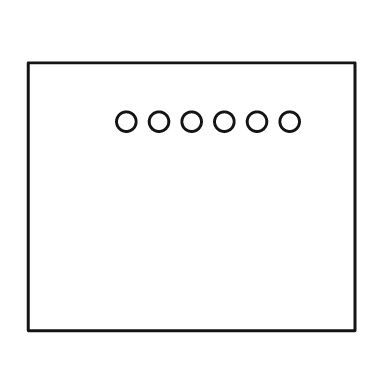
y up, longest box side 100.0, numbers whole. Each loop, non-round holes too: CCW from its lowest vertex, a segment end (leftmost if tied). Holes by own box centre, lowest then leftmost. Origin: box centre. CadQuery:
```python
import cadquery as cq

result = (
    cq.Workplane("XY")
    .moveTo(-50.0, -41.0)
    .lineTo(50.0, -41.0)
    .lineTo(50.0, 41.0)
    .lineTo(-50.0, 41.0)
    .close()
    .moveTo(-20.0, 23.0)
    .circle(3.0)
    .moveTo(-10.0, 23.0)
    .circle(3.0)
    .moveTo(0.0, 23.0)
    .circle(3.0)
    .moveTo(10.0, 23.0)
    .circle(3.0)
    .moveTo(20.0, 23.0)
    .circle(3.0)
    .moveTo(30.0, 23.0)
    .circle(3.0)
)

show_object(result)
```